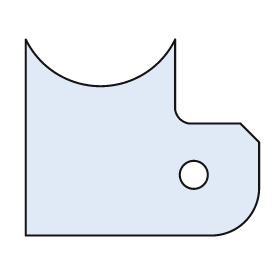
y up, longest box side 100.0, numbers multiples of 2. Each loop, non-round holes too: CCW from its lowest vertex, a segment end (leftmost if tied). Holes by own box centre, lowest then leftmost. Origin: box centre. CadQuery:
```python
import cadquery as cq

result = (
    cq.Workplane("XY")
    .moveTo(-50.0, -42.0)
    .lineTo(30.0, -42.0)
    .threePointArc((44.0, -36.0), (50.0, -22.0))
    .lineTo(50.0, -2.0)
    .lineTo(42.0, 6.0)
    .lineTo(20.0, 6.0)
    .threePointArc((16.0, 8.0), (14.0, 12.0))
    .lineTo(14.0, 42.0)
    .threePointArc((-18.0, 22.0), (-50.0, 42.0))
    .close()
    .moveTo(22.0, -16.0)
    .circle(6.0)
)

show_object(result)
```